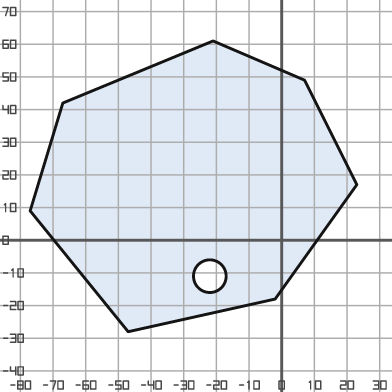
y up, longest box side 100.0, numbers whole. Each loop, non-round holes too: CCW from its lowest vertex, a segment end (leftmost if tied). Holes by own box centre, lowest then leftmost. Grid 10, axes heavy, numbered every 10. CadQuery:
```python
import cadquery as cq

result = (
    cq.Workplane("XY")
    .moveTo(-47.0, -28.0)
    .lineTo(-2.0, -18.0)
    .lineTo(23.0, 17.0)
    .lineTo(7.0, 49.0)
    .lineTo(-21.0, 61.0)
    .lineTo(-67.0, 42.0)
    .lineTo(-77.0, 9.0)
    .close()
    .moveTo(-22.0, -11.0)
    .circle(5.0)
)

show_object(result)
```